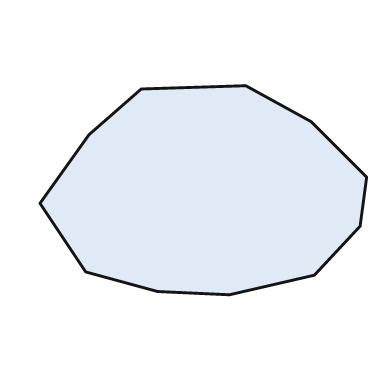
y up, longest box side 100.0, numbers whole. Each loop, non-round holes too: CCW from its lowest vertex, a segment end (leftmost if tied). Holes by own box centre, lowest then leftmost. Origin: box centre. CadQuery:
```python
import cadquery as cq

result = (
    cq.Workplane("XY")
    .moveTo(8.0, -32.0)
    .lineTo(34.0, -26.0)
    .lineTo(48.0, -11.0)
    .lineTo(50.0, 4.0)
    .lineTo(33.0, 21.0)
    .lineTo(13.0, 32.0)
    .lineTo(-19.0, 31.0)
    .lineTo(-35.0, 17.0)
    .lineTo(-50.0, -4.0)
    .lineTo(-36.0, -25.0)
    .lineTo(-14.0, -31.0)
    .close()
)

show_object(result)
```